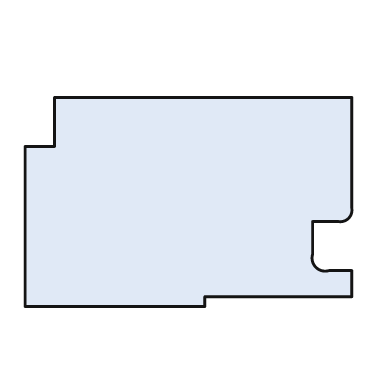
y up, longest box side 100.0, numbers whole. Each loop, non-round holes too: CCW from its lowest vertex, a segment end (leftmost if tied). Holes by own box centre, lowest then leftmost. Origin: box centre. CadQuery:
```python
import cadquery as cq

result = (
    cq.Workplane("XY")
    .moveTo(-50.0, -32.0)
    .lineTo(5.0, -32.0)
    .lineTo(5.0, -29.0)
    .lineTo(50.0, -29.0)
    .lineTo(50.0, -21.0)
    .lineTo(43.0, -21.0)
    .threePointArc((39.0, -20.0), (38.0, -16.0))
    .lineTo(38.0, -6.0)
    .lineTo(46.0, -6.0)
    .threePointArc((49.0, -5.0), (50.0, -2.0))
    .lineTo(50.0, 32.0)
    .lineTo(-41.0, 32.0)
    .lineTo(-41.0, 17.0)
    .lineTo(-50.0, 17.0)
    .close()
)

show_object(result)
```